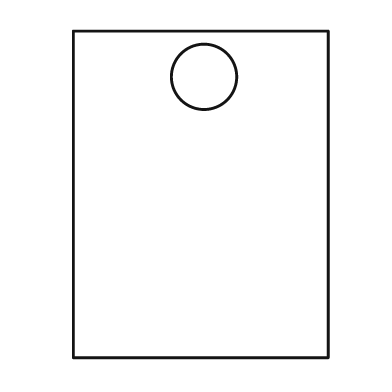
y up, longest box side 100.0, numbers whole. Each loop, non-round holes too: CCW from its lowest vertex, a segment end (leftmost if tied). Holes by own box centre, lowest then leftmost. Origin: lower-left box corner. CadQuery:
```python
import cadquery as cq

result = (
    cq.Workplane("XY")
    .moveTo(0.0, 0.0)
    .lineTo(78.0, 0.0)
    .lineTo(78.0, 100.0)
    .lineTo(0.0, 100.0)
    .close()
    .moveTo(40.0, 86.0)
    .circle(10.0)
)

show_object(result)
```